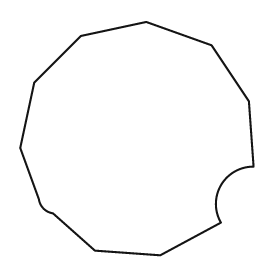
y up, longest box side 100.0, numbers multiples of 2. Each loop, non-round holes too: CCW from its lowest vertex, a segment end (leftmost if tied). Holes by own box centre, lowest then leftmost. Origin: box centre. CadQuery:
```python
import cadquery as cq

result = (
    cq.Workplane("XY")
    .moveTo(10.0, -50.0)
    .lineTo(36.0, -36.0)
    .threePointArc((36.0, -20.0), (50.0, -12.0))
    .lineTo(48.0, 16.0)
    .lineTo(32.0, 40.0)
    .lineTo(4.0, 50.0)
    .lineTo(-24.0, 44.0)
    .lineTo(-44.0, 24.0)
    .lineTo(-50.0, -4.0)
    .lineTo(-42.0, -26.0)
    .threePointArc((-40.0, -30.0), (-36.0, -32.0))
    .lineTo(-18.0, -48.0)
    .close()
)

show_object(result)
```